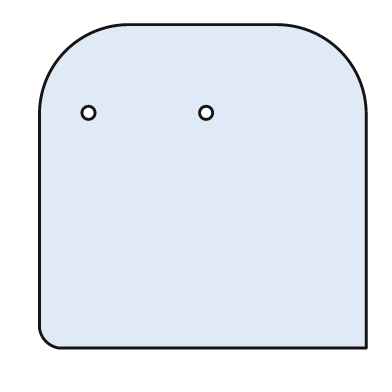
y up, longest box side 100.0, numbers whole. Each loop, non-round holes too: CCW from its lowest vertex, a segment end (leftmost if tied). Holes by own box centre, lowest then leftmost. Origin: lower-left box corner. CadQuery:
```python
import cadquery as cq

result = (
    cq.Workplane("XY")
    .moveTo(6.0, 0.0)
    .lineTo(100.0, 0.0)
    .lineTo(100.0, 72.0)
    .threePointArc((92.0, 91.0), (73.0, 99.0))
    .lineTo(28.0, 99.0)
    .threePointArc((8.0, 91.0), (0.0, 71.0))
    .lineTo(0.0, 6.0)
    .threePointArc((2.0, 2.0), (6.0, 0.0))
    .close()
    .moveTo(15.0, 72.0)
    .circle(2.0)
    .moveTo(51.0, 72.0)
    .circle(2.0)
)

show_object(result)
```